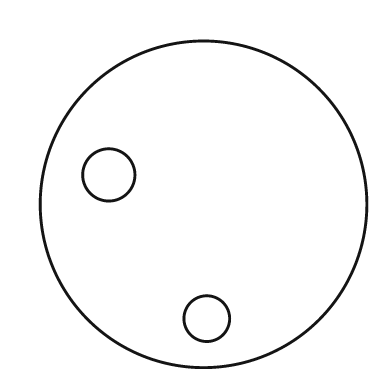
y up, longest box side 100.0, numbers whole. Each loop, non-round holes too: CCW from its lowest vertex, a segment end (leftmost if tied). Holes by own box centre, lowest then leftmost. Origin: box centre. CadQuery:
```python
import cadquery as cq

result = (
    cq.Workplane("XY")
    .moveTo(0.0, 0.0)
    .circle(50.0)
    .moveTo(1.0, -35.0)
    .circle(7.0)
    .moveTo(-29.0, 9.0)
    .circle(8.0)
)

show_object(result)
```